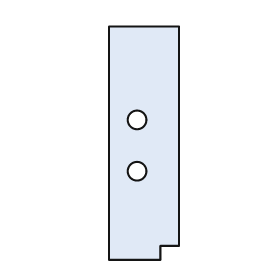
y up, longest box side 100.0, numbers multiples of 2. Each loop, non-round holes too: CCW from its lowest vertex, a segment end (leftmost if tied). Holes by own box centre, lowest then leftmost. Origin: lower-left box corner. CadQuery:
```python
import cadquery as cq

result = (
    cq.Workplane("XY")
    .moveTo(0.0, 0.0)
    .lineTo(22.0, 0.0)
    .lineTo(22.0, 6.0)
    .lineTo(30.0, 6.0)
    .lineTo(30.0, 100.0)
    .lineTo(0.0, 100.0)
    .close()
    .moveTo(12.0, 38.0)
    .circle(4.0)
    .moveTo(12.0, 60.0)
    .circle(4.0)
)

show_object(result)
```